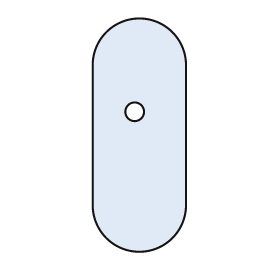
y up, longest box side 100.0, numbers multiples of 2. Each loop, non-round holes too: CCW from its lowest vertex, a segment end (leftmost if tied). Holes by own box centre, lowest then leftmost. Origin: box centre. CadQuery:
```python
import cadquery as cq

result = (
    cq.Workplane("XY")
    .moveTo(-20.0, -30.0)
    .threePointArc((0.0, -50.0), (20.0, -30.0))
    .lineTo(20.0, 30.0)
    .threePointArc((0.0, 50.0), (-20.0, 30.0))
    .close()
    .moveTo(-2.0, 10.0)
    .circle(4.0)
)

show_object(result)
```